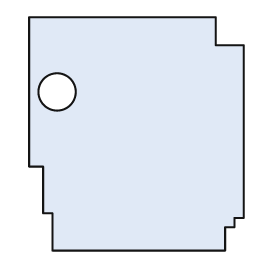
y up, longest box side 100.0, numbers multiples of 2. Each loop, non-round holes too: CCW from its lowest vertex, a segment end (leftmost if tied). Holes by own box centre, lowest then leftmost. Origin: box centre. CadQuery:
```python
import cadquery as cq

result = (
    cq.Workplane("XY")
    .moveTo(-36.0, -50.0)
    .lineTo(38.0, -50.0)
    .lineTo(38.0, -40.0)
    .lineTo(42.0, -40.0)
    .lineTo(42.0, -36.0)
    .lineTo(46.0, -36.0)
    .lineTo(46.0, 38.0)
    .lineTo(34.0, 38.0)
    .lineTo(34.0, 50.0)
    .lineTo(-46.0, 50.0)
    .lineTo(-46.0, -14.0)
    .lineTo(-40.0, -14.0)
    .lineTo(-40.0, -34.0)
    .lineTo(-36.0, -34.0)
    .close()
    .moveTo(-34.0, 18.0)
    .circle(8.0)
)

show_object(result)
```